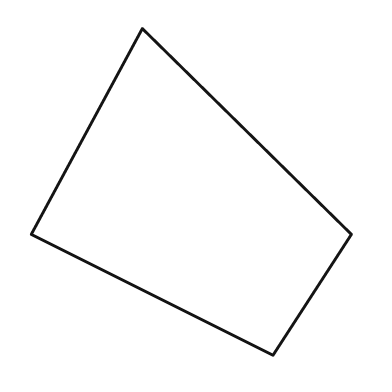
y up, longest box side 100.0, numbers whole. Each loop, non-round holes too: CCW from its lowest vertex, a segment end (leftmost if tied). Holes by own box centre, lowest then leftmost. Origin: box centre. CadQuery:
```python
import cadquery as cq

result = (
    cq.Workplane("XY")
    .moveTo(25.0, -50.0)
    .lineTo(49.0, -13.0)
    .lineTo(-15.0, 50.0)
    .lineTo(-49.0, -13.0)
    .close()
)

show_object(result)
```